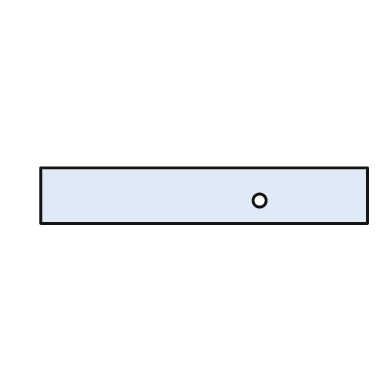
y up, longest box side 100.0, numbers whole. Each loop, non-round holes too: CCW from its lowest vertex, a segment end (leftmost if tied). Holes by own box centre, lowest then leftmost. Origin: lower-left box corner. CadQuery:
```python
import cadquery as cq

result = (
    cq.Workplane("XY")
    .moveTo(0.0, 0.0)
    .lineTo(100.0, 0.0)
    .lineTo(100.0, 17.0)
    .lineTo(0.0, 17.0)
    .close()
    .moveTo(67.0, 7.0)
    .circle(2.0)
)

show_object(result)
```